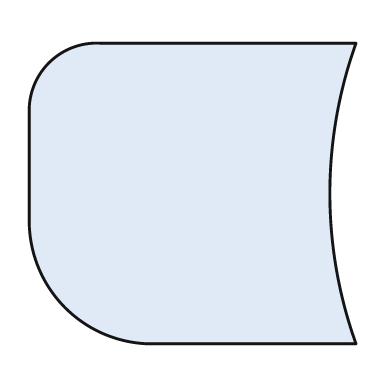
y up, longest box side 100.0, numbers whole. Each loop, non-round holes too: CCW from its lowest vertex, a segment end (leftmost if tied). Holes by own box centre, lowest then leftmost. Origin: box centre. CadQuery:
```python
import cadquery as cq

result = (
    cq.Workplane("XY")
    .moveTo(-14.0, -46.0)
    .lineTo(50.0, -46.0)
    .threePointArc((42.0, 0.0), (50.0, 46.0))
    .lineTo(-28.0, 46.0)
    .threePointArc((-44.0, 40.0), (-50.0, 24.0))
    .lineTo(-50.0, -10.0)
    .threePointArc((-39.0, -35.0), (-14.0, -46.0))
    .close()
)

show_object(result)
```